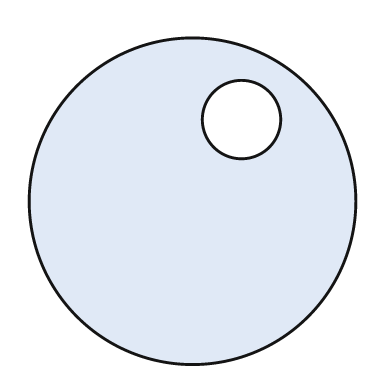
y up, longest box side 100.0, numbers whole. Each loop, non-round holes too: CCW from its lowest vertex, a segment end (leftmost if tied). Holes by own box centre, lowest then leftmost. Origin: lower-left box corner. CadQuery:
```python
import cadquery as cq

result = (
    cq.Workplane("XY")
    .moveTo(50.0, 50.0)
    .circle(50.0)
    .moveTo(65.0, 75.0)
    .circle(12.0)
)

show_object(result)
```